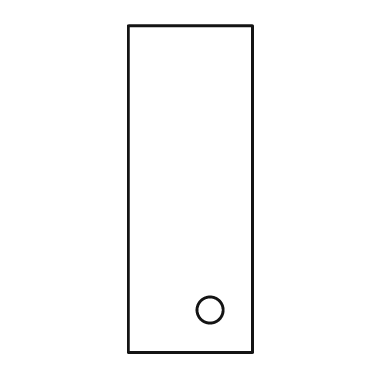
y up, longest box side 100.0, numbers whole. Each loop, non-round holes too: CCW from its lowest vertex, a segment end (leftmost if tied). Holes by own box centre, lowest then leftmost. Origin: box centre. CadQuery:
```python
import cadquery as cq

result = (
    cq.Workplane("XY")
    .moveTo(-19.0, -50.0)
    .lineTo(19.0, -50.0)
    .lineTo(19.0, 50.0)
    .lineTo(-19.0, 50.0)
    .close()
    .moveTo(6.0, -37.0)
    .circle(4.0)
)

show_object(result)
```